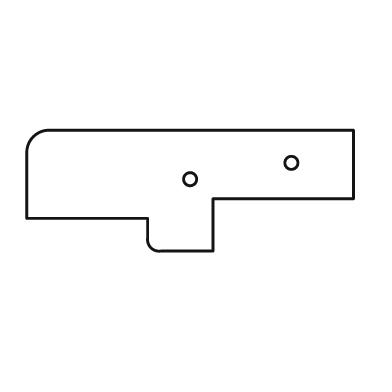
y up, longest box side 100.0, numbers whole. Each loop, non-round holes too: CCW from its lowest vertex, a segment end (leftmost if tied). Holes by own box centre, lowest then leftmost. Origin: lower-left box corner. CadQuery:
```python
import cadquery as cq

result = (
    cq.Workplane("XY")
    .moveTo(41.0, 0.0)
    .lineTo(57.0, 0.0)
    .lineTo(57.0, 16.0)
    .lineTo(100.0, 16.0)
    .lineTo(100.0, 37.0)
    .lineTo(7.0, 37.0)
    .threePointArc((2.0, 35.0), (0.0, 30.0))
    .lineTo(0.0, 10.0)
    .lineTo(37.0, 10.0)
    .lineTo(37.0, 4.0)
    .threePointArc((38.0, 1.0), (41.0, 0.0))
    .close()
    .moveTo(50.0, 22.0)
    .circle(2.0)
    .moveTo(81.0, 27.0)
    .circle(2.0)
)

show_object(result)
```